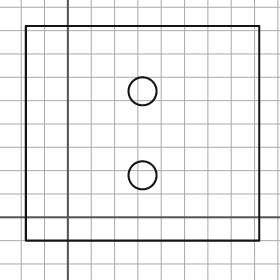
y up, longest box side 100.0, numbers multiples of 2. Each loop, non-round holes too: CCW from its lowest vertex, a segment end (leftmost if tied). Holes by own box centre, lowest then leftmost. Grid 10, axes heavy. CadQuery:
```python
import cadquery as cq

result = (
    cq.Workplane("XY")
    .moveTo(-18.0, -10.0)
    .lineTo(82.0, -10.0)
    .lineTo(82.0, 82.0)
    .lineTo(-18.0, 82.0)
    .close()
    .moveTo(32.0, 18.0)
    .circle(6.0)
    .moveTo(32.0, 54.0)
    .circle(6.0)
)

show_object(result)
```